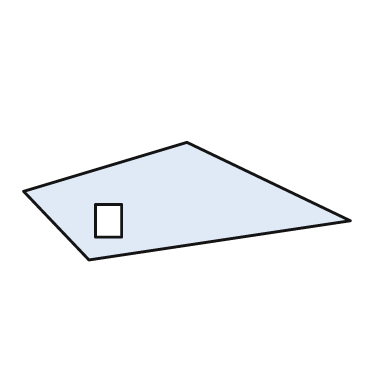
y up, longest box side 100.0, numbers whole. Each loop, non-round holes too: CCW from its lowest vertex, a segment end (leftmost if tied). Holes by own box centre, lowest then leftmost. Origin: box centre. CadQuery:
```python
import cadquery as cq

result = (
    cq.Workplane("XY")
    .moveTo(-30.0, -18.0)
    .lineTo(50.0, -6.0)
    .lineTo(0.0, 18.0)
    .lineTo(-50.0, 3.0)
    .close()
    .moveTo(-28.0, -11.0)
    .lineTo(-20.0, -11.0)
    .lineTo(-20.0, -1.0)
    .lineTo(-28.0, -1.0)
    .close()
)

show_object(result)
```